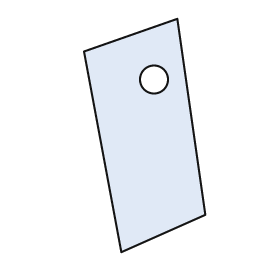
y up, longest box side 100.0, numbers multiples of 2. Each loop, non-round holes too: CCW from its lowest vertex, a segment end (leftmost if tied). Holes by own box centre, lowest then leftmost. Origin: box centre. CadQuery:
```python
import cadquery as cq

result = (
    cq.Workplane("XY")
    .moveTo(-10.0, -50.0)
    .lineTo(26.0, -34.0)
    .lineTo(14.0, 50.0)
    .lineTo(-26.0, 36.0)
    .close()
    .moveTo(4.0, 24.0)
    .circle(6.0)
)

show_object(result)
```